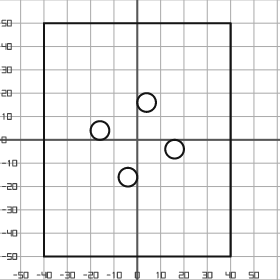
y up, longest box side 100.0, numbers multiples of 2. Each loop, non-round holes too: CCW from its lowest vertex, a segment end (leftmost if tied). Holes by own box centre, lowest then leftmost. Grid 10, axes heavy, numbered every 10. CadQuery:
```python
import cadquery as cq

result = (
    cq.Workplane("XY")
    .moveTo(-40.0, -50.0)
    .lineTo(40.0, -50.0)
    .lineTo(40.0, 50.0)
    .lineTo(-40.0, 50.0)
    .close()
    .moveTo(-4.0, -16.0)
    .circle(4.0)
    .moveTo(16.0, -4.0)
    .circle(4.0)
    .moveTo(-16.0, 4.0)
    .circle(4.0)
    .moveTo(4.0, 16.0)
    .circle(4.0)
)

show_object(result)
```